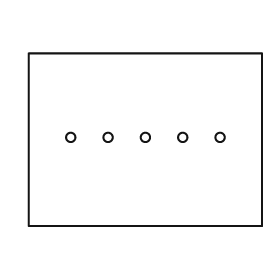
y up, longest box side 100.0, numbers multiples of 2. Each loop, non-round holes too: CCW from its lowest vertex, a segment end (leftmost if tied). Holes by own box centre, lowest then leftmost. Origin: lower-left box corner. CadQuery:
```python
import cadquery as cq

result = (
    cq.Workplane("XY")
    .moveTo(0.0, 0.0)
    .lineTo(100.0, 0.0)
    .lineTo(100.0, 74.0)
    .lineTo(0.0, 74.0)
    .close()
    .moveTo(18.0, 38.0)
    .circle(2.0)
    .moveTo(34.0, 38.0)
    .circle(2.0)
    .moveTo(50.0, 38.0)
    .circle(2.0)
    .moveTo(66.0, 38.0)
    .circle(2.0)
    .moveTo(82.0, 38.0)
    .circle(2.0)
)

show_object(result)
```